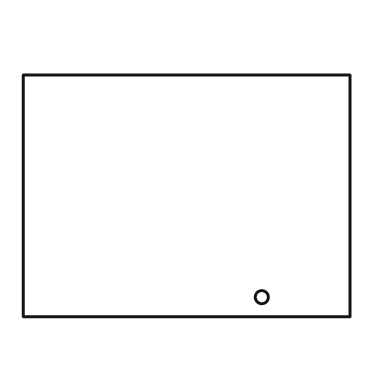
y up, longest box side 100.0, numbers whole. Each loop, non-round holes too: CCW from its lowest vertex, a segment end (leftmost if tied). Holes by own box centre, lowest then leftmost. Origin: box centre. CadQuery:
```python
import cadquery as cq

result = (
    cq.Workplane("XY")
    .moveTo(-50.0, -37.0)
    .lineTo(50.0, -37.0)
    .lineTo(50.0, 37.0)
    .lineTo(-50.0, 37.0)
    .close()
    .moveTo(23.0, -31.0)
    .circle(2.0)
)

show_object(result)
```